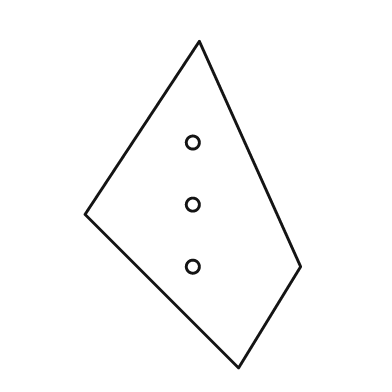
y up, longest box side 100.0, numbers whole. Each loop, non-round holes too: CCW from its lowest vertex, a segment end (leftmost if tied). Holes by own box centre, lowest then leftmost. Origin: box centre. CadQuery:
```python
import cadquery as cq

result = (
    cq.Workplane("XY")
    .moveTo(14.0, -50.0)
    .lineTo(33.0, -19.0)
    .lineTo(2.0, 50.0)
    .lineTo(-33.0, -3.0)
    .close()
    .moveTo(0.0, -19.0)
    .circle(2.0)
    .moveTo(0.0, 0.0)
    .circle(2.0)
    .moveTo(0.0, 19.0)
    .circle(2.0)
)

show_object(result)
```